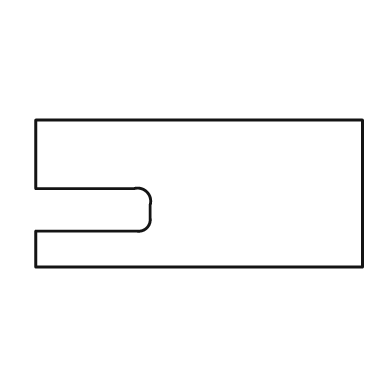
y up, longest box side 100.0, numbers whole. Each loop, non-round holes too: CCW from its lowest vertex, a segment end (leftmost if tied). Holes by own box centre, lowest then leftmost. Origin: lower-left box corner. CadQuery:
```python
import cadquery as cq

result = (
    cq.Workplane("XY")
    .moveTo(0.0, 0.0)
    .lineTo(100.0, 0.0)
    .lineTo(100.0, 45.0)
    .lineTo(0.0, 45.0)
    .lineTo(0.0, 24.0)
    .lineTo(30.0, 24.0)
    .threePointArc((34.0, 23.0), (35.0, 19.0))
    .lineTo(35.0, 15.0)
    .threePointArc((34.0, 12.0), (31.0, 11.0))
    .lineTo(0.0, 11.0)
    .close()
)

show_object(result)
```